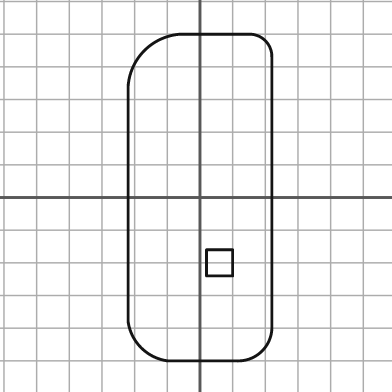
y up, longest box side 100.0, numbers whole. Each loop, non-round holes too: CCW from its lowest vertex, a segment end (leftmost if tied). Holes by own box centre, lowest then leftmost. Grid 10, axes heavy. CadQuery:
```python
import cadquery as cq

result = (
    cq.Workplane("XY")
    .moveTo(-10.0, -50.0)
    .lineTo(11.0, -50.0)
    .threePointArc((19.0, -47.0), (22.0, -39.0))
    .lineTo(22.0, 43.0)
    .threePointArc((20.0, 48.0), (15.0, 50.0))
    .lineTo(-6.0, 50.0)
    .threePointArc((-17.0, 45.0), (-22.0, 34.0))
    .lineTo(-22.0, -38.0)
    .threePointArc((-18.0, -46.0), (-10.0, -50.0))
    .close()
    .moveTo(2.0, -24.0)
    .lineTo(10.0, -24.0)
    .lineTo(10.0, -16.0)
    .lineTo(2.0, -16.0)
    .close()
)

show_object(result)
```